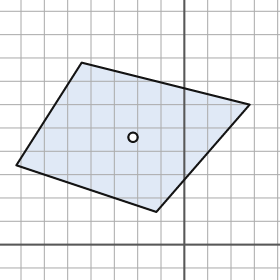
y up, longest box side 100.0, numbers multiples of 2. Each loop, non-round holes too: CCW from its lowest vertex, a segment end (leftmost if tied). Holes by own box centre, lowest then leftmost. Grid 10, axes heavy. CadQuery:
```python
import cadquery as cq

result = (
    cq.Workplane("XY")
    .moveTo(-12.0, 14.0)
    .lineTo(28.0, 60.0)
    .lineTo(-44.0, 78.0)
    .lineTo(-72.0, 34.0)
    .close()
    .moveTo(-22.0, 46.0)
    .circle(2.0)
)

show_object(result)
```